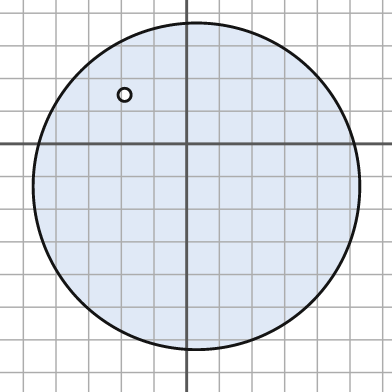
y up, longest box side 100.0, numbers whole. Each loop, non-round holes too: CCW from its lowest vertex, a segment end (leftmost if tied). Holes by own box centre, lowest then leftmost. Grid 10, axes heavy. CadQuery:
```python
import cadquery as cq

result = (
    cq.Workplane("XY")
    .moveTo(3.0, -13.0)
    .circle(50.0)
    .moveTo(-19.0, 15.0)
    .circle(2.0)
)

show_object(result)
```